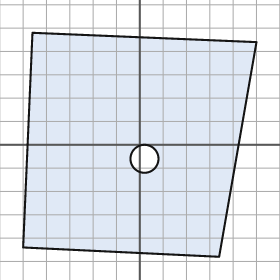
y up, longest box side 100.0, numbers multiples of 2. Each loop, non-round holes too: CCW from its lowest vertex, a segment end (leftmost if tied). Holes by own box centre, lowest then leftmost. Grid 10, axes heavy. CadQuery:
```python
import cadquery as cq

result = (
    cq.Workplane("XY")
    .moveTo(34.0, -48.0)
    .lineTo(50.0, 44.0)
    .lineTo(-46.0, 48.0)
    .lineTo(-50.0, -44.0)
    .close()
    .moveTo(2.0, -6.0)
    .circle(6.0)
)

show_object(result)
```